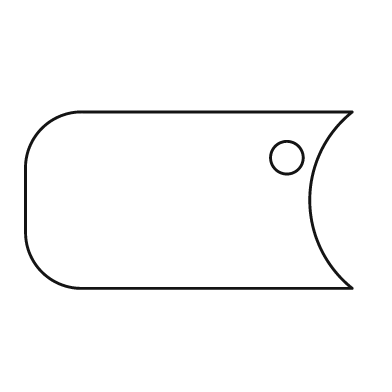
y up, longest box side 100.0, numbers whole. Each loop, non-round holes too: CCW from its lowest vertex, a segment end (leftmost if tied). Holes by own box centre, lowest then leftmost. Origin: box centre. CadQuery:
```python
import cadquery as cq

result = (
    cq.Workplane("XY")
    .moveTo(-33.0, -27.0)
    .lineTo(50.0, -27.0)
    .threePointArc((37.0, 0.0), (50.0, 27.0))
    .lineTo(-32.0, 27.0)
    .threePointArc((-45.0, 22.0), (-50.0, 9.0))
    .lineTo(-50.0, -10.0)
    .threePointArc((-45.0, -22.0), (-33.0, -27.0))
    .close()
    .moveTo(30.0, 13.0)
    .circle(5.0)
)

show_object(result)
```